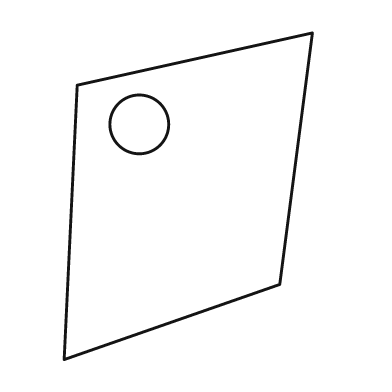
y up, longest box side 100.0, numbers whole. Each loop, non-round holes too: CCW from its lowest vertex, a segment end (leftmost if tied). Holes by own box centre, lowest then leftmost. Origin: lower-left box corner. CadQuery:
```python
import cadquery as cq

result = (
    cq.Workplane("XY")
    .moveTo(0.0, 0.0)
    .lineTo(66.0, 23.0)
    .lineTo(76.0, 100.0)
    .lineTo(4.0, 84.0)
    .close()
    .moveTo(23.0, 72.0)
    .circle(9.0)
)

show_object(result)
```